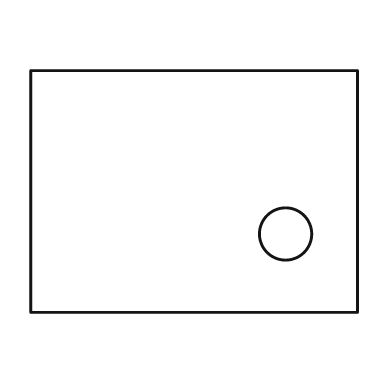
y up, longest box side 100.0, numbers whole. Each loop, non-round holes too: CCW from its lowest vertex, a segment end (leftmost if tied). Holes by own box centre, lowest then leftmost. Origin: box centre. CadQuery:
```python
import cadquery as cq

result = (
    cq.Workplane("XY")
    .moveTo(-50.0, -37.0)
    .lineTo(50.0, -37.0)
    .lineTo(50.0, 37.0)
    .lineTo(-50.0, 37.0)
    .close()
    .moveTo(28.0, -13.0)
    .circle(8.0)
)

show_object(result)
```